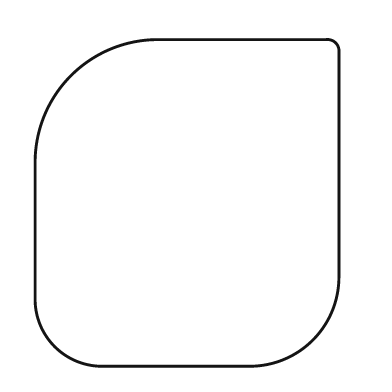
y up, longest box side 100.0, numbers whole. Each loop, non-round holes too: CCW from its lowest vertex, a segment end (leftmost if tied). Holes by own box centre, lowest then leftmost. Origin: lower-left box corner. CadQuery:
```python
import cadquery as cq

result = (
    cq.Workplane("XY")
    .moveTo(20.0, 0.0)
    .lineTo(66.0, 0.0)
    .threePointArc((85.0, 8.0), (93.0, 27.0))
    .lineTo(93.0, 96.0)
    .threePointArc((92.0, 99.0), (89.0, 100.0))
    .lineTo(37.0, 100.0)
    .threePointArc((11.0, 89.0), (0.0, 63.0))
    .lineTo(0.0, 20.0)
    .threePointArc((6.0, 6.0), (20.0, 0.0))
    .close()
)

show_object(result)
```